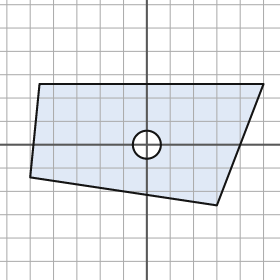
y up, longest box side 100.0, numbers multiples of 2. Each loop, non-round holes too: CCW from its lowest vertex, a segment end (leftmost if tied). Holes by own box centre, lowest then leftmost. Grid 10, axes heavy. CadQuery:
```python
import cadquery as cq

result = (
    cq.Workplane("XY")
    .moveTo(30.0, -26.0)
    .lineTo(50.0, 26.0)
    .lineTo(-46.0, 26.0)
    .lineTo(-50.0, -14.0)
    .close()
    .moveTo(0.0, 0.0)
    .circle(6.0)
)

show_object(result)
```